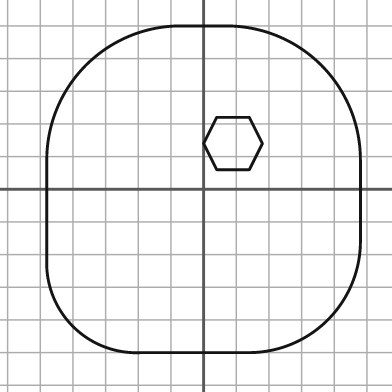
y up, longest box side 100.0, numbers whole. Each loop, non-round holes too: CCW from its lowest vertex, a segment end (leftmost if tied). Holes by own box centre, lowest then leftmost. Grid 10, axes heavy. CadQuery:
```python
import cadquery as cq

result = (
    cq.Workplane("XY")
    .moveTo(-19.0, -50.0)
    .lineTo(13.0, -50.0)
    .threePointArc((38.0, -40.0), (48.0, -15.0))
    .lineTo(48.0, 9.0)
    .threePointArc((36.0, 38.0), (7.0, 50.0))
    .lineTo(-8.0, 50.0)
    .threePointArc((-36.0, 38.0), (-48.0, 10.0))
    .lineTo(-48.0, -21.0)
    .threePointArc((-40.0, -42.0), (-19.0, -50.0))
    .close()
    .moveTo(4.0, 6.0)
    .lineTo(14.0, 6.0)
    .lineTo(18.0, 14.0)
    .lineTo(14.0, 22.0)
    .lineTo(4.0, 22.0)
    .lineTo(0.0, 14.0)
    .close()
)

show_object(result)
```